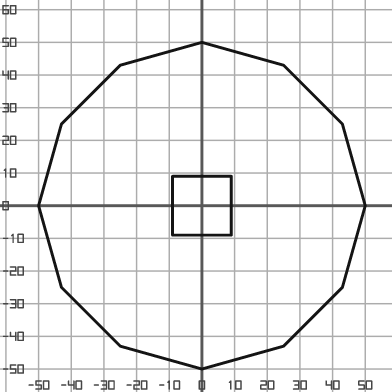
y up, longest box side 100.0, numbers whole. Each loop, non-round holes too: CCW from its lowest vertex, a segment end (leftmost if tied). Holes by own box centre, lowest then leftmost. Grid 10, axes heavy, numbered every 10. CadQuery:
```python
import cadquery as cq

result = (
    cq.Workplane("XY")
    .moveTo(0.0, -50.0)
    .lineTo(25.0, -43.0)
    .lineTo(43.0, -25.0)
    .lineTo(50.0, 0.0)
    .lineTo(43.0, 25.0)
    .lineTo(25.0, 43.0)
    .lineTo(0.0, 50.0)
    .lineTo(-25.0, 43.0)
    .lineTo(-43.0, 25.0)
    .lineTo(-50.0, 0.0)
    .lineTo(-43.0, -25.0)
    .lineTo(-25.0, -43.0)
    .close()
    .moveTo(-9.0, -9.0)
    .lineTo(9.0, -9.0)
    .lineTo(9.0, 9.0)
    .lineTo(-9.0, 9.0)
    .close()
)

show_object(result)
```